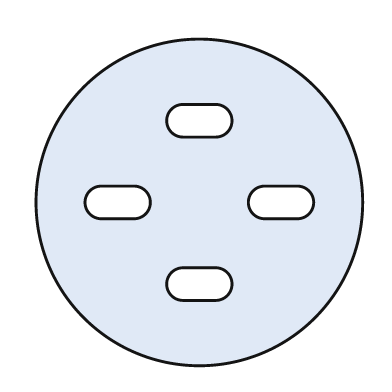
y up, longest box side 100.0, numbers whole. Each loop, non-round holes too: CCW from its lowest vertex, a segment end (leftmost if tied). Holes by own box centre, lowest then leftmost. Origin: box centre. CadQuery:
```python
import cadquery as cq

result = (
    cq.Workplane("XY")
    .moveTo(0.0, 0.0)
    .circle(50.0)
    .moveTo(-5.0, -30.0)
    .lineTo(5.0, -30.0)
    .threePointArc((10.0, -25.0), (5.0, -20.0))
    .lineTo(-5.0, -20.0)
    .threePointArc((-10.0, -25.0), (-5.0, -30.0))
    .close()
    .moveTo(-30.0, -5.0)
    .lineTo(-20.0, -5.0)
    .threePointArc((-15.0, 0.0), (-20.0, 5.0))
    .lineTo(-30.0, 5.0)
    .threePointArc((-35.0, 0.0), (-30.0, -5.0))
    .close()
    .moveTo(20.0, -5.0)
    .lineTo(30.0, -5.0)
    .threePointArc((35.0, 0.0), (30.0, 5.0))
    .lineTo(20.0, 5.0)
    .threePointArc((15.0, 0.0), (20.0, -5.0))
    .close()
    .moveTo(-5.0, 20.0)
    .lineTo(5.0, 20.0)
    .threePointArc((10.0, 25.0), (5.0, 30.0))
    .lineTo(-5.0, 30.0)
    .threePointArc((-10.0, 25.0), (-5.0, 20.0))
    .close()
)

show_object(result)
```